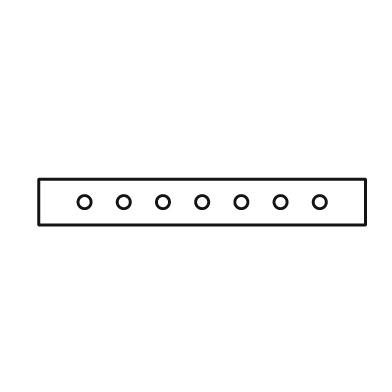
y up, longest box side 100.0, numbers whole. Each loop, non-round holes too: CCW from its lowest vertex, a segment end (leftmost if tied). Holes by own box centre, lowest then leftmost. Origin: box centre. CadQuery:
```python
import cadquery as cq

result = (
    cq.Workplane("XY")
    .moveTo(-50.0, -7.0)
    .lineTo(50.0, -7.0)
    .lineTo(50.0, 7.0)
    .lineTo(-50.0, 7.0)
    .close()
    .moveTo(-36.0, 0.0)
    .circle(2.0)
    .moveTo(-24.0, 0.0)
    .circle(2.0)
    .moveTo(-12.0, 0.0)
    .circle(2.0)
    .moveTo(0.0, 0.0)
    .circle(2.0)
    .moveTo(12.0, 0.0)
    .circle(2.0)
    .moveTo(24.0, 0.0)
    .circle(2.0)
    .moveTo(36.0, 0.0)
    .circle(2.0)
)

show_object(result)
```